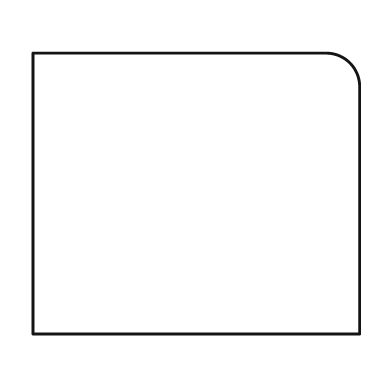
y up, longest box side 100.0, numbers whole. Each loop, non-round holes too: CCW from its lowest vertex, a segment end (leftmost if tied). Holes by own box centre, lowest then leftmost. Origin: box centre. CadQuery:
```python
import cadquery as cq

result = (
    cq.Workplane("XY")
    .moveTo(-50.0, -43.0)
    .lineTo(50.0, -43.0)
    .lineTo(50.0, 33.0)
    .threePointArc((47.0, 40.0), (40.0, 43.0))
    .lineTo(-50.0, 43.0)
    .close()
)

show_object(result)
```